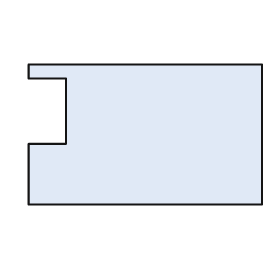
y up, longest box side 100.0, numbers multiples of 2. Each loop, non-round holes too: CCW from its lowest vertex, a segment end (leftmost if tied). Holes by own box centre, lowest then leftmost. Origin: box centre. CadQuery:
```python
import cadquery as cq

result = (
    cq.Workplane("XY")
    .moveTo(-50.0, -30.0)
    .lineTo(50.0, -30.0)
    .lineTo(50.0, 30.0)
    .lineTo(-50.0, 30.0)
    .lineTo(-50.0, 24.0)
    .lineTo(-34.0, 24.0)
    .lineTo(-34.0, -4.0)
    .lineTo(-50.0, -4.0)
    .close()
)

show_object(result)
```